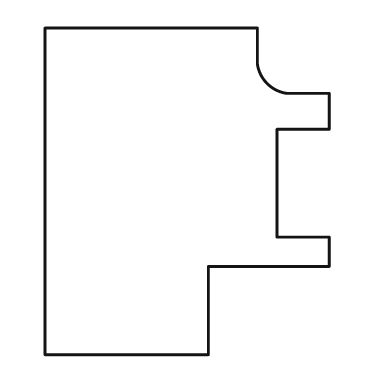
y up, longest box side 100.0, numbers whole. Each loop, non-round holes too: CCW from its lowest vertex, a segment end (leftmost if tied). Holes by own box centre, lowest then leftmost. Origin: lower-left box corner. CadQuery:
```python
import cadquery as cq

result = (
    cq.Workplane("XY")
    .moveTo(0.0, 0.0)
    .lineTo(50.0, 0.0)
    .lineTo(50.0, 27.0)
    .lineTo(87.0, 27.0)
    .lineTo(87.0, 36.0)
    .lineTo(71.0, 36.0)
    .lineTo(71.0, 69.0)
    .lineTo(87.0, 69.0)
    .lineTo(87.0, 80.0)
    .lineTo(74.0, 80.0)
    .threePointArc((68.0, 83.0), (65.0, 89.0))
    .lineTo(65.0, 100.0)
    .lineTo(0.0, 100.0)
    .close()
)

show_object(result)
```